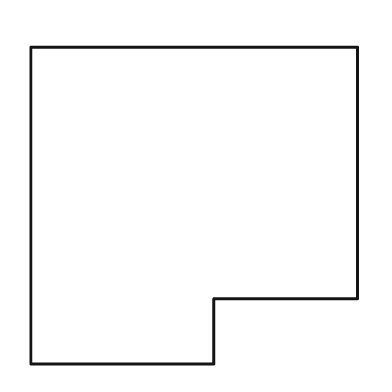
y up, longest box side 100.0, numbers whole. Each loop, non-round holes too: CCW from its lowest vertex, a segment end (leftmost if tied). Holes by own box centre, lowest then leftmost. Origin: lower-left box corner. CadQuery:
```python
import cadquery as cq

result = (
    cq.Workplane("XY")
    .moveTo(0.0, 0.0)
    .lineTo(56.0, 0.0)
    .lineTo(56.0, 20.0)
    .lineTo(100.0, 20.0)
    .lineTo(100.0, 97.0)
    .lineTo(0.0, 97.0)
    .close()
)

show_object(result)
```